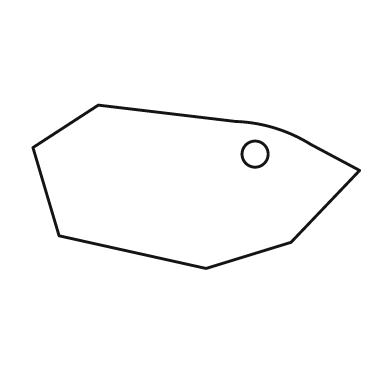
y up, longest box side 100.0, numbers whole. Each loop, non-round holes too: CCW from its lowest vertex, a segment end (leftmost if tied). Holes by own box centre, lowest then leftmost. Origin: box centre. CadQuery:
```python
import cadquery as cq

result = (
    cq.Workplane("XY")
    .moveTo(3.0, -25.0)
    .lineTo(29.0, -17.0)
    .lineTo(50.0, 5.0)
    .lineTo(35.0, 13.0)
    .threePointArc((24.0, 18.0), (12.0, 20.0))
    .lineTo(-30.0, 25.0)
    .lineTo(-50.0, 12.0)
    .lineTo(-42.0, -15.0)
    .close()
    .moveTo(18.0, 10.0)
    .circle(4.0)
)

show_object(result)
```